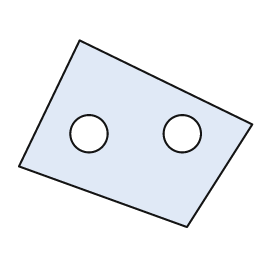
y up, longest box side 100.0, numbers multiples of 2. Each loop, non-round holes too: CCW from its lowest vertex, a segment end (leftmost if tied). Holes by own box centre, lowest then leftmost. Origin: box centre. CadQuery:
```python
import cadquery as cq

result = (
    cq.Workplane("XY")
    .moveTo(22.0, -40.0)
    .lineTo(50.0, 4.0)
    .lineTo(-24.0, 40.0)
    .lineTo(-50.0, -14.0)
    .close()
    .moveTo(-20.0, 0.0)
    .circle(8.0)
    .moveTo(20.0, 0.0)
    .circle(8.0)
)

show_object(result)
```